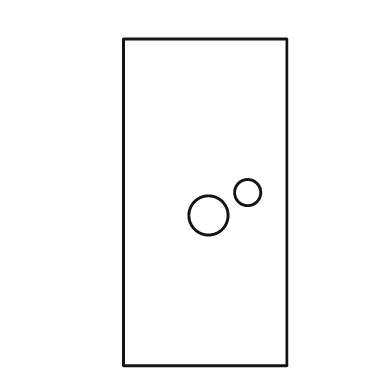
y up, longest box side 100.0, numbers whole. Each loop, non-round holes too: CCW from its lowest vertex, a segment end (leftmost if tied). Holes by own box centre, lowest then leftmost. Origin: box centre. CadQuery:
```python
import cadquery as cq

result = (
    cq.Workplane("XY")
    .moveTo(-25.0, -50.0)
    .lineTo(25.0, -50.0)
    .lineTo(25.0, 50.0)
    .lineTo(-25.0, 50.0)
    .close()
    .moveTo(1.0, -4.0)
    .circle(6.0)
    .moveTo(13.0, 3.0)
    .circle(4.0)
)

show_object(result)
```